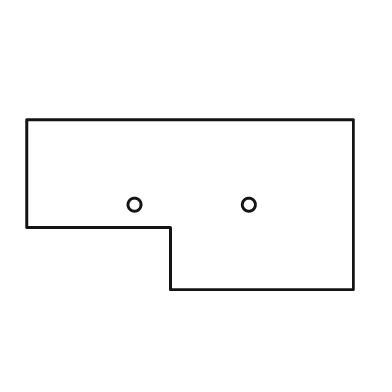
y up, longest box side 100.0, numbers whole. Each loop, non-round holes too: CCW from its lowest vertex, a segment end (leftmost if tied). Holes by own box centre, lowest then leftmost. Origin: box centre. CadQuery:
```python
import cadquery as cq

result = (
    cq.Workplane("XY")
    .moveTo(-6.0, -26.0)
    .lineTo(50.0, -26.0)
    .lineTo(50.0, 26.0)
    .lineTo(-50.0, 26.0)
    .lineTo(-50.0, -7.0)
    .lineTo(-6.0, -7.0)
    .close()
    .moveTo(-17.0, 0.0)
    .circle(2.0)
    .moveTo(18.0, 0.0)
    .circle(2.0)
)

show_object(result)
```